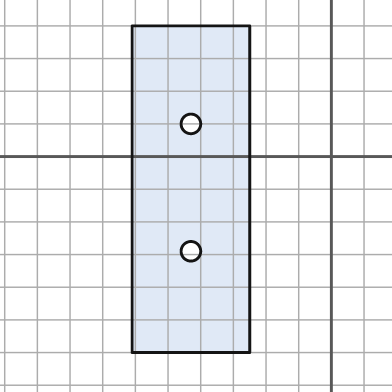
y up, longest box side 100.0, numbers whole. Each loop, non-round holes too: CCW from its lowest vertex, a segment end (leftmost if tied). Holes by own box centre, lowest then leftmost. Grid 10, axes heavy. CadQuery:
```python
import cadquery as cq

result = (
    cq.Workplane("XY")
    .moveTo(-61.0, -60.0)
    .lineTo(-25.0, -60.0)
    .lineTo(-25.0, 40.0)
    .lineTo(-61.0, 40.0)
    .close()
    .moveTo(-43.0, -29.0)
    .circle(3.0)
    .moveTo(-43.0, 10.0)
    .circle(3.0)
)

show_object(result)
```